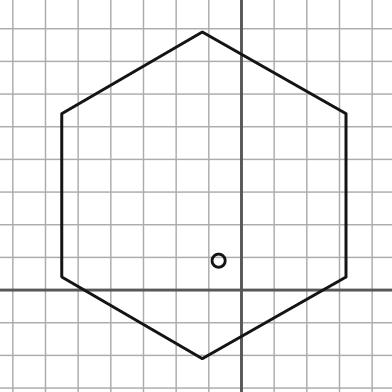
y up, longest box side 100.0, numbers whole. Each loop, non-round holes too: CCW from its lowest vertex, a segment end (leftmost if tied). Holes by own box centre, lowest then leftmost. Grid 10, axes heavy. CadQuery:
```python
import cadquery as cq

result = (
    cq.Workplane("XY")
    .moveTo(-12.0, -21.0)
    .lineTo(32.0, 4.0)
    .lineTo(32.0, 54.0)
    .lineTo(-12.0, 79.0)
    .lineTo(-55.0, 54.0)
    .lineTo(-55.0, 4.0)
    .close()
    .moveTo(-7.0, 9.0)
    .circle(2.0)
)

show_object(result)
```